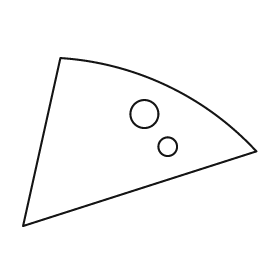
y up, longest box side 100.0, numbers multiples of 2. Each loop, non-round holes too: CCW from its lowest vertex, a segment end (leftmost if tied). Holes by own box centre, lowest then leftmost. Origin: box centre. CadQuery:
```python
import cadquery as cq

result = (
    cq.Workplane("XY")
    .moveTo(-50.0, -36.0)
    .lineTo(50.0, -4.0)
    .threePointArc((12.0, 24.0), (-34.0, 36.0))
    .close()
    .moveTo(12.0, -2.0)
    .circle(4.0)
    .moveTo(2.0, 12.0)
    .circle(6.0)
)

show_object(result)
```